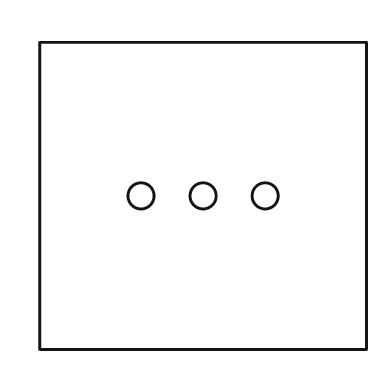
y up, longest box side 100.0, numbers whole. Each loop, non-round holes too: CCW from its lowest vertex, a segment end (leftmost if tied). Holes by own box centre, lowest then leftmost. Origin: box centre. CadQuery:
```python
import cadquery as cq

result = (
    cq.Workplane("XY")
    .moveTo(-50.0, -47.0)
    .lineTo(50.0, -47.0)
    .lineTo(50.0, 47.0)
    .lineTo(-50.0, 47.0)
    .close()
    .moveTo(-19.0, 0.0)
    .circle(4.0)
    .moveTo(0.0, 0.0)
    .circle(4.0)
    .moveTo(19.0, 0.0)
    .circle(4.0)
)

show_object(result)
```